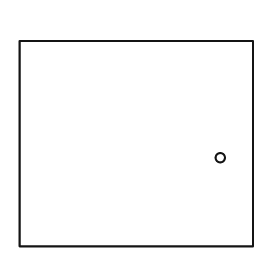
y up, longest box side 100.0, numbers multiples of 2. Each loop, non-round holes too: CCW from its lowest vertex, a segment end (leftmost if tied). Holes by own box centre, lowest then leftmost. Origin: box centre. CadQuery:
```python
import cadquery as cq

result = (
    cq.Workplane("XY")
    .moveTo(-50.0, -44.0)
    .lineTo(50.0, -44.0)
    .lineTo(50.0, 44.0)
    .lineTo(-50.0, 44.0)
    .close()
    .moveTo(36.0, -6.0)
    .circle(2.0)
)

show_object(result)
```